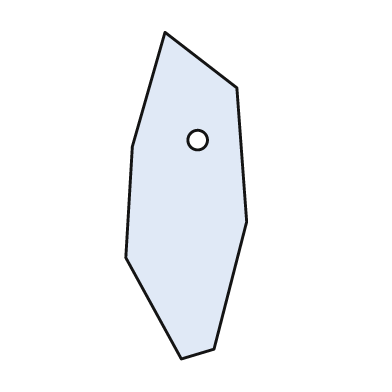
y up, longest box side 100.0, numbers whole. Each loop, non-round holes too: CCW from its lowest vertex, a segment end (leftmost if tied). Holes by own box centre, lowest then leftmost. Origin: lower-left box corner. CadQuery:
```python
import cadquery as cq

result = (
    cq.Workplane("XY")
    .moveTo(17.0, 0.0)
    .lineTo(27.0, 3.0)
    .lineTo(37.0, 42.0)
    .lineTo(34.0, 83.0)
    .lineTo(12.0, 100.0)
    .lineTo(2.0, 65.0)
    .lineTo(0.0, 31.0)
    .close()
    .moveTo(22.0, 67.0)
    .circle(3.0)
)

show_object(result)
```